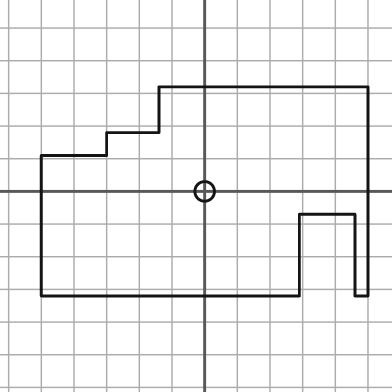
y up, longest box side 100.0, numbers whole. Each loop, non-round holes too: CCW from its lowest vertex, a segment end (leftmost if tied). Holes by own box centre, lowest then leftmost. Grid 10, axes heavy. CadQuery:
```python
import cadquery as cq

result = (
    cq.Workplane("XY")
    .moveTo(-50.0, -32.0)
    .lineTo(29.0, -32.0)
    .lineTo(29.0, -7.0)
    .lineTo(46.0, -7.0)
    .lineTo(46.0, -32.0)
    .lineTo(50.0, -32.0)
    .lineTo(50.0, 32.0)
    .lineTo(-14.0, 32.0)
    .lineTo(-14.0, 18.0)
    .lineTo(-30.0, 18.0)
    .lineTo(-30.0, 11.0)
    .lineTo(-50.0, 11.0)
    .close()
    .moveTo(0.0, 0.0)
    .circle(3.0)
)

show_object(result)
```